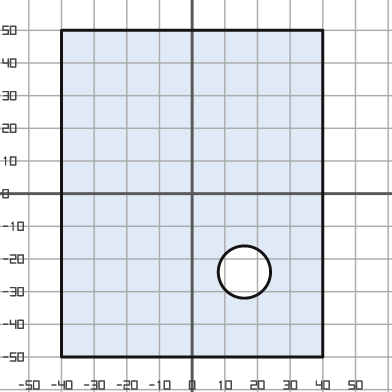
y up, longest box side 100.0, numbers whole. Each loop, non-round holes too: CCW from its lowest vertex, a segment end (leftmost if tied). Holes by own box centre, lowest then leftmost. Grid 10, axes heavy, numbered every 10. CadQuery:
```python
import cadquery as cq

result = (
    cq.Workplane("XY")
    .moveTo(-40.0, -50.0)
    .lineTo(40.0, -50.0)
    .lineTo(40.0, 50.0)
    .lineTo(-40.0, 50.0)
    .close()
    .moveTo(16.0, -24.0)
    .circle(8.0)
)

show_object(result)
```